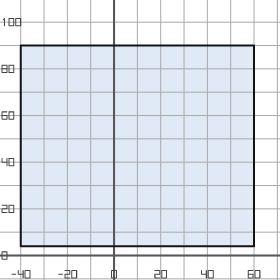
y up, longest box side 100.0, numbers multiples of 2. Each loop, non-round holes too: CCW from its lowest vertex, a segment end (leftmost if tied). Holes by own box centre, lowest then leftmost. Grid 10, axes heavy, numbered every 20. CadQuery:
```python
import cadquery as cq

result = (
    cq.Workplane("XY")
    .moveTo(-40.0, 4.0)
    .lineTo(60.0, 4.0)
    .lineTo(60.0, 90.0)
    .lineTo(-40.0, 90.0)
    .close()
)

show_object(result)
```